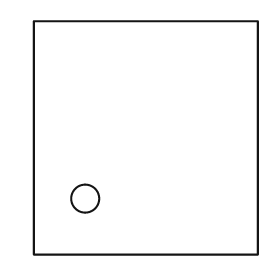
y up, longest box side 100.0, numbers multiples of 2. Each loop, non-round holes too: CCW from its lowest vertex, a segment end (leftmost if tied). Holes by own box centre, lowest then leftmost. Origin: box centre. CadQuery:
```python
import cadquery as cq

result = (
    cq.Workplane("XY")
    .moveTo(-48.0, -50.0)
    .lineTo(48.0, -50.0)
    .lineTo(48.0, 50.0)
    .lineTo(-48.0, 50.0)
    .close()
    .moveTo(-26.0, -26.0)
    .circle(6.0)
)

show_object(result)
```